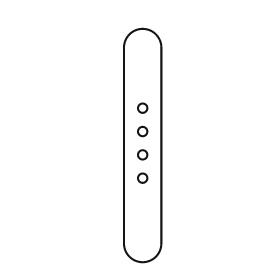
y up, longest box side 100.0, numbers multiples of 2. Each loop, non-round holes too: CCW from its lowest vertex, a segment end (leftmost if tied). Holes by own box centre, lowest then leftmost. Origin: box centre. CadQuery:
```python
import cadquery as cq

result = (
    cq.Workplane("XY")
    .moveTo(-8.0, -42.0)
    .threePointArc((0.0, -50.0), (8.0, -42.0))
    .lineTo(8.0, 42.0)
    .threePointArc((0.0, 50.0), (-8.0, 42.0))
    .close()
    .moveTo(0.0, -14.0)
    .circle(2.0)
    .moveTo(0.0, -4.0)
    .circle(2.0)
    .moveTo(0.0, 6.0)
    .circle(2.0)
    .moveTo(0.0, 16.0)
    .circle(2.0)
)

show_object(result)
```